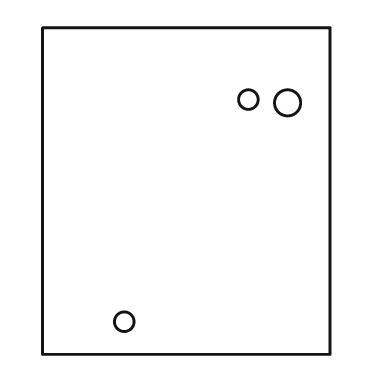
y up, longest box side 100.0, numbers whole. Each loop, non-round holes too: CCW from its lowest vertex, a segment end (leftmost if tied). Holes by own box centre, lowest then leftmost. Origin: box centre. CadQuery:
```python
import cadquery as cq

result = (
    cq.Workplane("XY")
    .moveTo(-44.0, -50.0)
    .lineTo(44.0, -50.0)
    .lineTo(44.0, 50.0)
    .lineTo(-44.0, 50.0)
    .close()
    .moveTo(-19.0, -40.0)
    .circle(3.0)
    .moveTo(31.0, 27.0)
    .circle(4.0)
    .moveTo(19.0, 28.0)
    .circle(3.0)
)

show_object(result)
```